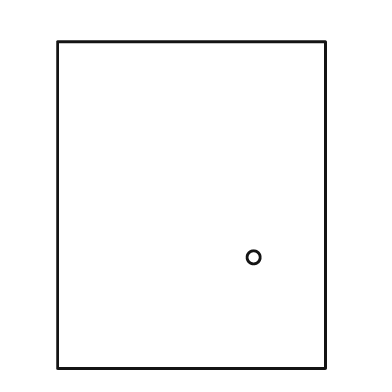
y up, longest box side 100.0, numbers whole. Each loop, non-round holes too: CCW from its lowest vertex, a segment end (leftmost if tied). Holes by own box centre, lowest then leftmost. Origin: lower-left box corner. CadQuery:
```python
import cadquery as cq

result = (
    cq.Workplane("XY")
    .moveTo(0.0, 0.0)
    .lineTo(82.0, 0.0)
    .lineTo(82.0, 100.0)
    .lineTo(0.0, 100.0)
    .close()
    .moveTo(60.0, 34.0)
    .circle(2.0)
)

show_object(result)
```